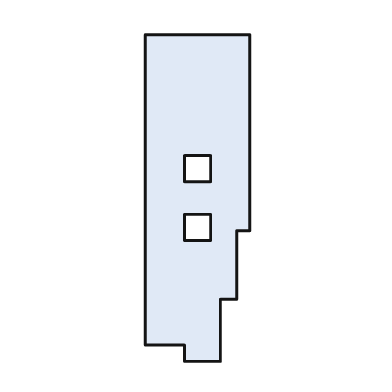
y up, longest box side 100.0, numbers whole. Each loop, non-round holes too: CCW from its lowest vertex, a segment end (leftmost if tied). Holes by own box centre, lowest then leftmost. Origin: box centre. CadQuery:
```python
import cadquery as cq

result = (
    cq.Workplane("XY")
    .moveTo(-4.0, -50.0)
    .lineTo(7.0, -50.0)
    .lineTo(7.0, -31.0)
    .lineTo(12.0, -31.0)
    .lineTo(12.0, -10.0)
    .lineTo(16.0, -10.0)
    .lineTo(16.0, 50.0)
    .lineTo(-16.0, 50.0)
    .lineTo(-16.0, -45.0)
    .lineTo(-4.0, -45.0)
    .close()
    .moveTo(-4.0, -13.0)
    .lineTo(4.0, -13.0)
    .lineTo(4.0, -5.0)
    .lineTo(-4.0, -5.0)
    .close()
    .moveTo(-4.0, 5.0)
    .lineTo(4.0, 5.0)
    .lineTo(4.0, 13.0)
    .lineTo(-4.0, 13.0)
    .close()
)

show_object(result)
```